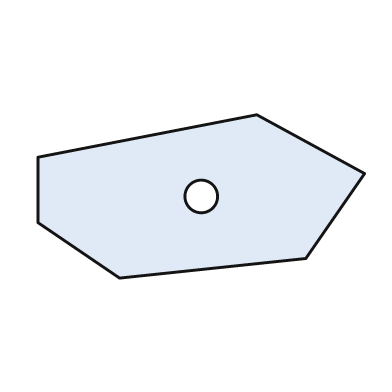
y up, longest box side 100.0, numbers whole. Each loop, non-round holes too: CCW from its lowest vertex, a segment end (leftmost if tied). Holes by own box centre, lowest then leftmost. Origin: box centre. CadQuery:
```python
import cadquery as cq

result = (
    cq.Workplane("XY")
    .moveTo(-25.0, -25.0)
    .lineTo(32.0, -19.0)
    .lineTo(50.0, 7.0)
    .lineTo(17.0, 25.0)
    .lineTo(-50.0, 12.0)
    .lineTo(-50.0, -8.0)
    .close()
    .moveTo(0.0, 0.0)
    .circle(5.0)
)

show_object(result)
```